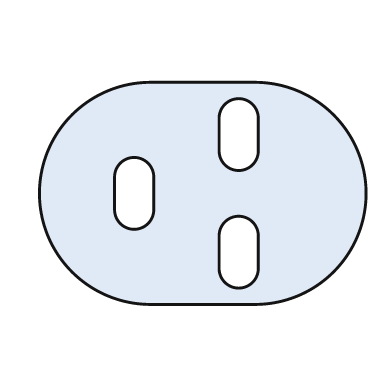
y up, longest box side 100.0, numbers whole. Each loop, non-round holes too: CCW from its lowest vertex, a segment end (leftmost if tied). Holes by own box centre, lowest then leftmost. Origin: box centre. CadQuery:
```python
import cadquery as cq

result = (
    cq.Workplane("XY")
    .moveTo(-16.0, -34.0)
    .lineTo(16.0, -34.0)
    .threePointArc((50.0, 0.0), (16.0, 34.0))
    .lineTo(-16.0, 34.0)
    .threePointArc((-50.0, 0.0), (-16.0, -34.0))
    .close()
    .moveTo(5.0, -23.0)
    .threePointArc((11.0, -29.0), (17.0, -23.0))
    .lineTo(17.0, -13.0)
    .threePointArc((11.0, -7.0), (5.0, -13.0))
    .close()
    .moveTo(-27.0, -5.0)
    .threePointArc((-21.0, -11.0), (-15.0, -5.0))
    .lineTo(-15.0, 5.0)
    .threePointArc((-21.0, 11.0), (-27.0, 5.0))
    .close()
    .moveTo(5.0, 13.0)
    .threePointArc((11.0, 7.0), (17.0, 13.0))
    .lineTo(17.0, 23.0)
    .threePointArc((11.0, 29.0), (5.0, 23.0))
    .close()
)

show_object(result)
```